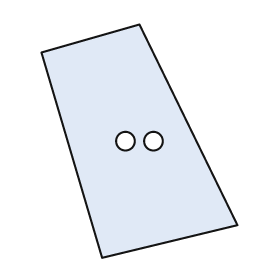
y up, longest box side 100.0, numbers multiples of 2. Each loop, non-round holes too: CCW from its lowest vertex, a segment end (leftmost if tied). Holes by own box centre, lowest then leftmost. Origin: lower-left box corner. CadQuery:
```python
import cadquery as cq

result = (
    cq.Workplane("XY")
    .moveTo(26.0, 0.0)
    .lineTo(84.0, 14.0)
    .lineTo(42.0, 100.0)
    .lineTo(0.0, 88.0)
    .close()
    .moveTo(36.0, 50.0)
    .circle(4.0)
    .moveTo(48.0, 50.0)
    .circle(4.0)
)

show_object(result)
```